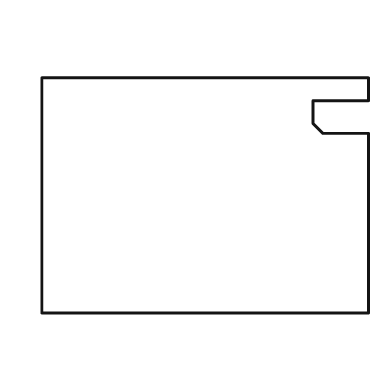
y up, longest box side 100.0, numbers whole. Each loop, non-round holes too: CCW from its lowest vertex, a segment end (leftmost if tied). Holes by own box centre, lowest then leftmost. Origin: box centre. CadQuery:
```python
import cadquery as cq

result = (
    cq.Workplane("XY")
    .moveTo(-50.0, -36.0)
    .lineTo(50.0, -36.0)
    .lineTo(50.0, 19.0)
    .lineTo(36.0, 19.0)
    .lineTo(33.0, 22.0)
    .lineTo(33.0, 29.0)
    .lineTo(50.0, 29.0)
    .lineTo(50.0, 36.0)
    .lineTo(-50.0, 36.0)
    .close()
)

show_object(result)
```